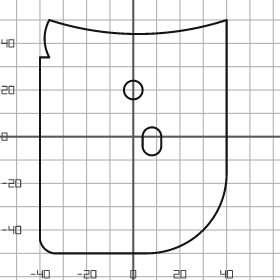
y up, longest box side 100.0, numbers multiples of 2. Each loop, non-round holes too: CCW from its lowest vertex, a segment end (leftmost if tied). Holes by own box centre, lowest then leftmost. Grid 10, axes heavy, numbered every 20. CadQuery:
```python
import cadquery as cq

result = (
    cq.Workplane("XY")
    .moveTo(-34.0, -50.0)
    .lineTo(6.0, -50.0)
    .threePointArc((30.0, -40.0), (40.0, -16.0))
    .lineTo(40.0, 50.0)
    .threePointArc((2.0, 44.0), (-36.0, 50.0))
    .threePointArc((-38.0, 42.0), (-36.0, 34.0))
    .lineTo(-40.0, 34.0)
    .lineTo(-40.0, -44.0)
    .threePointArc((-38.0, -48.0), (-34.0, -50.0))
    .close()
    .moveTo(4.0, -4.0)
    .threePointArc((8.0, -8.0), (12.0, -4.0))
    .lineTo(12.0, 0.0)
    .threePointArc((8.0, 4.0), (4.0, 0.0))
    .close()
    .moveTo(0.0, 20.0)
    .circle(4.0)
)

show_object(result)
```